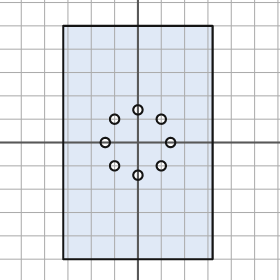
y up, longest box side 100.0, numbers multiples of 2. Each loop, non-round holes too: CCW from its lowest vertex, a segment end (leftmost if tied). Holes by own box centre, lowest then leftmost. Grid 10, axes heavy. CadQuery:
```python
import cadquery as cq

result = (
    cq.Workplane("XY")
    .moveTo(-32.0, -50.0)
    .lineTo(32.0, -50.0)
    .lineTo(32.0, 50.0)
    .lineTo(-32.0, 50.0)
    .close()
    .moveTo(0.0, -14.0)
    .circle(2.0)
    .moveTo(-10.0, -10.0)
    .circle(2.0)
    .moveTo(10.0, -10.0)
    .circle(2.0)
    .moveTo(-14.0, 0.0)
    .circle(2.0)
    .moveTo(14.0, 0.0)
    .circle(2.0)
    .moveTo(-10.0, 10.0)
    .circle(2.0)
    .moveTo(10.0, 10.0)
    .circle(2.0)
    .moveTo(0.0, 14.0)
    .circle(2.0)
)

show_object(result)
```